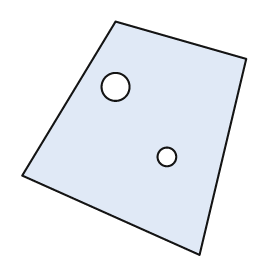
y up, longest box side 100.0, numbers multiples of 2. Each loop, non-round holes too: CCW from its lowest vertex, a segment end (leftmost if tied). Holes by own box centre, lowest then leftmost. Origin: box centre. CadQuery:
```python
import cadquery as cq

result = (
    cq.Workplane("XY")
    .moveTo(28.0, -50.0)
    .lineTo(48.0, 34.0)
    .lineTo(-8.0, 50.0)
    .lineTo(-48.0, -16.0)
    .close()
    .moveTo(14.0, -8.0)
    .circle(4.0)
    .moveTo(-8.0, 22.0)
    .circle(6.0)
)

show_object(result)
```